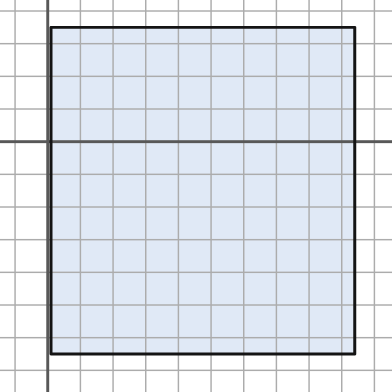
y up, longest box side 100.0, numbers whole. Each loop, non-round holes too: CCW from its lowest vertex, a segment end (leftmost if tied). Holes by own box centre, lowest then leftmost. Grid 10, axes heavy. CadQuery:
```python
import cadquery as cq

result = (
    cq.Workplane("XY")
    .moveTo(1.0, -65.0)
    .lineTo(94.0, -65.0)
    .lineTo(94.0, 35.0)
    .lineTo(1.0, 35.0)
    .close()
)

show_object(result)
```